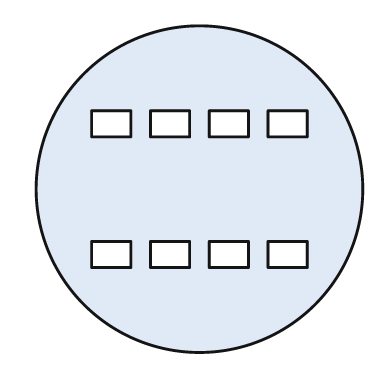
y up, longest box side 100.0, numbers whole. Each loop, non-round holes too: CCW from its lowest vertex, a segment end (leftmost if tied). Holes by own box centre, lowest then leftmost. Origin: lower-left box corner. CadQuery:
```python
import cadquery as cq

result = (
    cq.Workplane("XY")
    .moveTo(50.0, 50.0)
    .circle(50.0)
    .moveTo(17.0, 26.0)
    .lineTo(29.0, 26.0)
    .lineTo(29.0, 34.0)
    .lineTo(17.0, 34.0)
    .close()
    .moveTo(35.0, 26.0)
    .lineTo(47.0, 26.0)
    .lineTo(47.0, 34.0)
    .lineTo(35.0, 34.0)
    .close()
    .moveTo(53.0, 26.0)
    .lineTo(65.0, 26.0)
    .lineTo(65.0, 34.0)
    .lineTo(53.0, 34.0)
    .close()
    .moveTo(71.0, 26.0)
    .lineTo(83.0, 26.0)
    .lineTo(83.0, 34.0)
    .lineTo(71.0, 34.0)
    .close()
    .moveTo(17.0, 66.0)
    .lineTo(29.0, 66.0)
    .lineTo(29.0, 74.0)
    .lineTo(17.0, 74.0)
    .close()
    .moveTo(35.0, 66.0)
    .lineTo(47.0, 66.0)
    .lineTo(47.0, 74.0)
    .lineTo(35.0, 74.0)
    .close()
    .moveTo(53.0, 66.0)
    .lineTo(65.0, 66.0)
    .lineTo(65.0, 74.0)
    .lineTo(53.0, 74.0)
    .close()
    .moveTo(71.0, 66.0)
    .lineTo(83.0, 66.0)
    .lineTo(83.0, 74.0)
    .lineTo(71.0, 74.0)
    .close()
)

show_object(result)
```